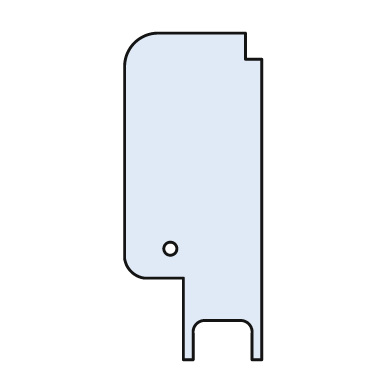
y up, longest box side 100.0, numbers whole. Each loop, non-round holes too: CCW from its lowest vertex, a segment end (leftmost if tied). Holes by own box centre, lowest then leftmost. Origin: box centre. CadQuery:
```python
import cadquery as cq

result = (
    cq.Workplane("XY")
    .moveTo(-3.0, -50.0)
    .lineTo(0.0, -50.0)
    .lineTo(0.0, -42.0)
    .threePointArc((1.0, -39.0), (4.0, -38.0))
    .lineTo(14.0, -38.0)
    .threePointArc((17.0, -39.0), (18.0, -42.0))
    .lineTo(18.0, -50.0)
    .lineTo(21.0, -50.0)
    .lineTo(21.0, 42.0)
    .lineTo(16.0, 42.0)
    .lineTo(16.0, 50.0)
    .lineTo(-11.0, 50.0)
    .threePointArc((-18.0, 47.0), (-21.0, 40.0))
    .lineTo(-21.0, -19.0)
    .threePointArc((-19.0, -23.0), (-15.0, -25.0))
    .lineTo(-3.0, -25.0)
    .close()
    .moveTo(-7.0, -16.0)
    .circle(2.0)
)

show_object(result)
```